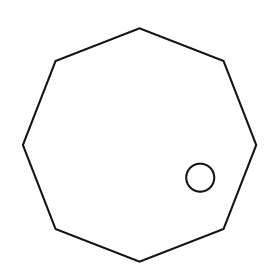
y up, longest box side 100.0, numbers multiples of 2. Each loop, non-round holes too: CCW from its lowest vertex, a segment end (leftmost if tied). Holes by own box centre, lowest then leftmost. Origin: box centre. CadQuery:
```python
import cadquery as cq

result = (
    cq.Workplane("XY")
    .moveTo(0.0, -50.0)
    .lineTo(36.0, -36.0)
    .lineTo(50.0, 0.0)
    .lineTo(36.0, 36.0)
    .lineTo(0.0, 50.0)
    .lineTo(-36.0, 36.0)
    .lineTo(-50.0, 0.0)
    .lineTo(-36.0, -36.0)
    .close()
    .moveTo(26.0, -14.0)
    .circle(6.0)
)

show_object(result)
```